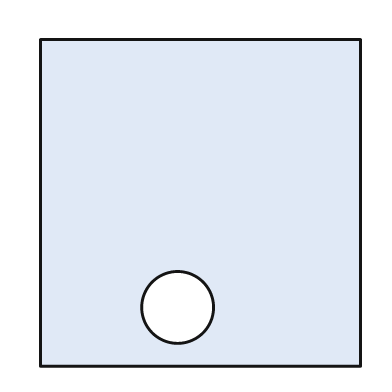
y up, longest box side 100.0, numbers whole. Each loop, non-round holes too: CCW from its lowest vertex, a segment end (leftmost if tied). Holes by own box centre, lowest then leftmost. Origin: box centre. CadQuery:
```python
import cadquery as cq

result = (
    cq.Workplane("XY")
    .moveTo(-49.0, -50.0)
    .lineTo(49.0, -50.0)
    .lineTo(49.0, 50.0)
    .lineTo(-49.0, 50.0)
    .close()
    .moveTo(-7.0, -32.0)
    .circle(11.0)
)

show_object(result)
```